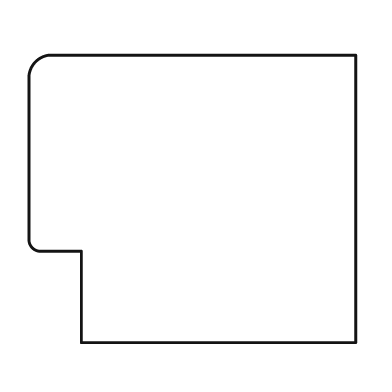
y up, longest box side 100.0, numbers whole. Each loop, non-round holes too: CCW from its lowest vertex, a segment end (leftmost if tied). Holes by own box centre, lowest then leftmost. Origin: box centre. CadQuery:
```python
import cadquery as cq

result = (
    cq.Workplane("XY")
    .moveTo(-34.0, -44.0)
    .lineTo(50.0, -44.0)
    .lineTo(50.0, 44.0)
    .lineTo(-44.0, 44.0)
    .threePointArc((-48.0, 42.0), (-50.0, 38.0))
    .lineTo(-50.0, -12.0)
    .threePointArc((-49.0, -15.0), (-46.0, -16.0))
    .lineTo(-34.0, -16.0)
    .close()
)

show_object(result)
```